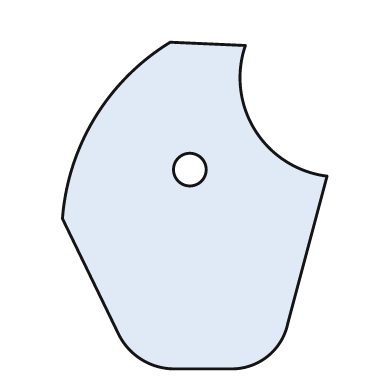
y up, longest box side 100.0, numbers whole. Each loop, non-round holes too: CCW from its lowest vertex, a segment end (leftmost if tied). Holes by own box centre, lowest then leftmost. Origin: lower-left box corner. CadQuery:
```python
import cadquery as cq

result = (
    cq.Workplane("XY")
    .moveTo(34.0, 0.0)
    .lineTo(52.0, 0.0)
    .threePointArc((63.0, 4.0), (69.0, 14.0))
    .lineTo(81.0, 59.0)
    .threePointArc((59.0, 73.0), (56.0, 99.0))
    .lineTo(33.0, 100.0)
    .threePointArc((10.0, 77.0), (0.0, 46.0))
    .lineTo(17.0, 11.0)
    .threePointArc((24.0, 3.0), (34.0, 0.0))
    .close()
    .moveTo(39.0, 61.0)
    .circle(5.0)
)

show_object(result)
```